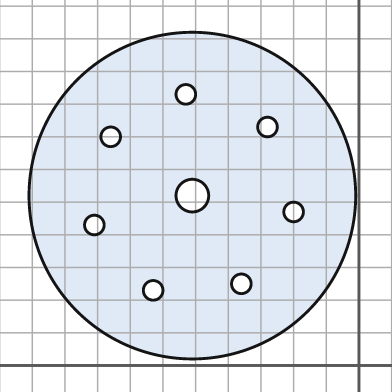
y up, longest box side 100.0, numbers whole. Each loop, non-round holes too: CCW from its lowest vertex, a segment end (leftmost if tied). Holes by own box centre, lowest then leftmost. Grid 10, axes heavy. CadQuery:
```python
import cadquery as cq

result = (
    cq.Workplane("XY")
    .moveTo(-51.0, 52.0)
    .circle(50.0)
    .moveTo(-63.0, 23.0)
    .circle(3.0)
    .moveTo(-36.0, 25.0)
    .circle(3.0)
    .moveTo(-81.0, 43.0)
    .circle(3.0)
    .moveTo(-20.0, 47.0)
    .circle(3.0)
    .moveTo(-51.0, 52.0)
    .circle(5.0)
    .moveTo(-76.0, 70.0)
    .circle(3.0)
    .moveTo(-28.0, 73.0)
    .circle(3.0)
    .moveTo(-53.0, 83.0)
    .circle(3.0)
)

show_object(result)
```